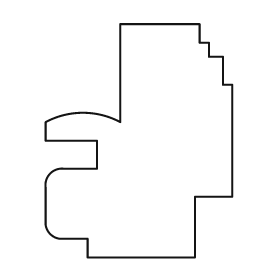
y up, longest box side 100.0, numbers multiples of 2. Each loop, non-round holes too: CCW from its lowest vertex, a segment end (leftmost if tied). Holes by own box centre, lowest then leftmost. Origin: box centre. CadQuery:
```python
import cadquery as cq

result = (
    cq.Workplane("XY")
    .moveTo(-22.0, -50.0)
    .lineTo(24.0, -50.0)
    .lineTo(24.0, -24.0)
    .lineTo(40.0, -24.0)
    .lineTo(40.0, 24.0)
    .lineTo(36.0, 24.0)
    .lineTo(36.0, 36.0)
    .lineTo(30.0, 36.0)
    .lineTo(30.0, 42.0)
    .lineTo(26.0, 42.0)
    .lineTo(26.0, 50.0)
    .lineTo(-8.0, 50.0)
    .lineTo(-8.0, 8.0)
    .threePointArc((-24.0, 12.0), (-40.0, 8.0))
    .lineTo(-40.0, 0.0)
    .lineTo(-18.0, 0.0)
    .lineTo(-18.0, -12.0)
    .lineTo(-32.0, -12.0)
    .threePointArc((-38.0, -14.0), (-40.0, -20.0))
    .lineTo(-40.0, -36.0)
    .threePointArc((-38.0, -40.0), (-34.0, -42.0))
    .lineTo(-22.0, -42.0)
    .close()
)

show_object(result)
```